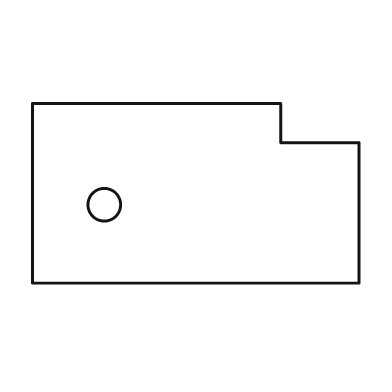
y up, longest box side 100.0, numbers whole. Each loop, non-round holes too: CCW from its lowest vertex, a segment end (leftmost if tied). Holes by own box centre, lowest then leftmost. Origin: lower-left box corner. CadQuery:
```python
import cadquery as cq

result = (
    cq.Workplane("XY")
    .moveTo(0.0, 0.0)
    .lineTo(100.0, 0.0)
    .lineTo(100.0, 43.0)
    .lineTo(76.0, 43.0)
    .lineTo(76.0, 55.0)
    .lineTo(0.0, 55.0)
    .close()
    .moveTo(22.0, 24.0)
    .circle(5.0)
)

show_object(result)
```